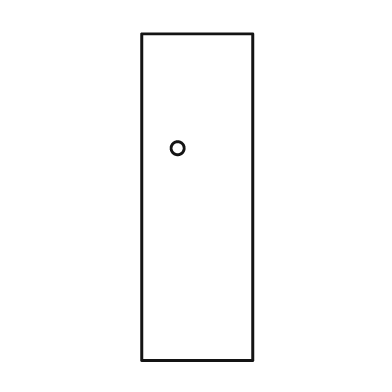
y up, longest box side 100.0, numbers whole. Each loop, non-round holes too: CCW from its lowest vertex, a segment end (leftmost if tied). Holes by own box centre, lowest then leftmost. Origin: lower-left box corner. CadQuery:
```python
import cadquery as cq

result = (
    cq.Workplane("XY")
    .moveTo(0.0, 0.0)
    .lineTo(34.0, 0.0)
    .lineTo(34.0, 100.0)
    .lineTo(0.0, 100.0)
    .close()
    .moveTo(11.0, 65.0)
    .circle(2.0)
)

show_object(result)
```